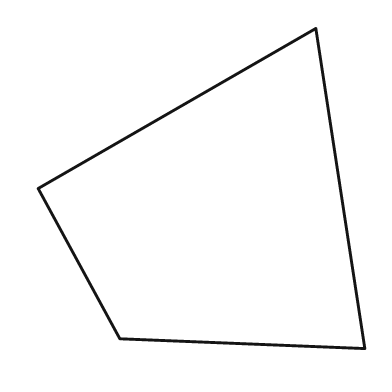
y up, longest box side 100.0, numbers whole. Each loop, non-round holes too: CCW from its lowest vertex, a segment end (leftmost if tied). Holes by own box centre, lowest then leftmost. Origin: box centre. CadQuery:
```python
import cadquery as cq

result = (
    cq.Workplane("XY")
    .moveTo(50.0, -49.0)
    .lineTo(35.0, 49.0)
    .lineTo(-50.0, 0.0)
    .lineTo(-25.0, -46.0)
    .close()
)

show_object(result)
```